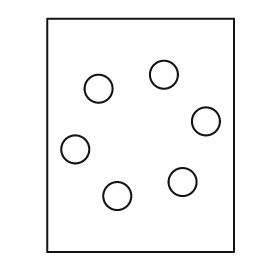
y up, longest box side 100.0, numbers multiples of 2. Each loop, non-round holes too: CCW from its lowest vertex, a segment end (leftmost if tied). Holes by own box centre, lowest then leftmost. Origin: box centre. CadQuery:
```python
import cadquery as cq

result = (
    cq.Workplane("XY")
    .moveTo(-40.0, -50.0)
    .lineTo(40.0, -50.0)
    .lineTo(40.0, 50.0)
    .lineTo(-40.0, 50.0)
    .close()
    .moveTo(-10.0, -26.0)
    .circle(6.0)
    .moveTo(18.0, -20.0)
    .circle(6.0)
    .moveTo(-28.0, -6.0)
    .circle(6.0)
    .moveTo(28.0, 6.0)
    .circle(6.0)
    .moveTo(-18.0, 20.0)
    .circle(6.0)
    .moveTo(10.0, 26.0)
    .circle(6.0)
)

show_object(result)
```